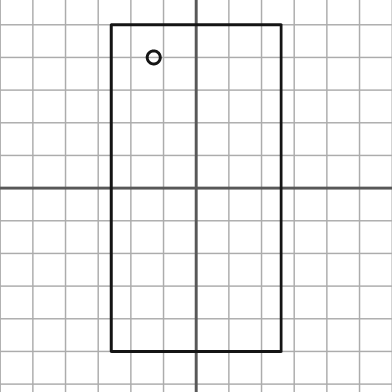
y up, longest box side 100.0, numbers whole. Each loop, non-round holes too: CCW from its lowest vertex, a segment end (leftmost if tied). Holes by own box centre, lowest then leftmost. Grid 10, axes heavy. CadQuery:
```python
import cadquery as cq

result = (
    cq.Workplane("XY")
    .moveTo(-26.0, -50.0)
    .lineTo(26.0, -50.0)
    .lineTo(26.0, 50.0)
    .lineTo(-26.0, 50.0)
    .close()
    .moveTo(-13.0, 40.0)
    .circle(2.0)
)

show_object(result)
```